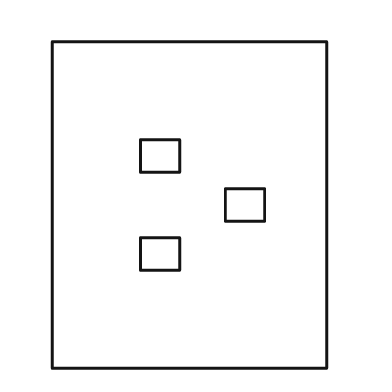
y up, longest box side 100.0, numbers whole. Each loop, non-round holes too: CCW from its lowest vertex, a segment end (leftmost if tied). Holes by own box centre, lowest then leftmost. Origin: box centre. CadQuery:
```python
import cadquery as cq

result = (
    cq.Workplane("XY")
    .moveTo(-42.0, -50.0)
    .lineTo(42.0, -50.0)
    .lineTo(42.0, 50.0)
    .lineTo(-42.0, 50.0)
    .close()
    .moveTo(-15.0, -20.0)
    .lineTo(-3.0, -20.0)
    .lineTo(-3.0, -10.0)
    .lineTo(-15.0, -10.0)
    .close()
    .moveTo(11.0, -5.0)
    .lineTo(23.0, -5.0)
    .lineTo(23.0, 5.0)
    .lineTo(11.0, 5.0)
    .close()
    .moveTo(-15.0, 10.0)
    .lineTo(-3.0, 10.0)
    .lineTo(-3.0, 20.0)
    .lineTo(-15.0, 20.0)
    .close()
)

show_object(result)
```